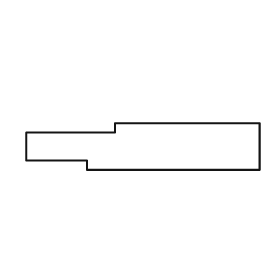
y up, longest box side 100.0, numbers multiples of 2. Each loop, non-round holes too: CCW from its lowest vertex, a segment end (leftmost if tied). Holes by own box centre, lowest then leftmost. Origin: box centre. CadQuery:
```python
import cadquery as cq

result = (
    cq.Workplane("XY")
    .moveTo(-24.0, -10.0)
    .lineTo(50.0, -10.0)
    .lineTo(50.0, 10.0)
    .lineTo(-12.0, 10.0)
    .lineTo(-12.0, 6.0)
    .lineTo(-50.0, 6.0)
    .lineTo(-50.0, -6.0)
    .lineTo(-24.0, -6.0)
    .close()
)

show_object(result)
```